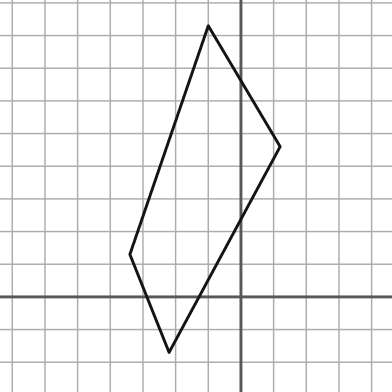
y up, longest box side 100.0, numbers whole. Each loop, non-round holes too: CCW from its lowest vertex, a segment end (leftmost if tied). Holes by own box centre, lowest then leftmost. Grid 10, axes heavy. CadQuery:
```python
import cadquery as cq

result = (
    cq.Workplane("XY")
    .moveTo(-22.0, -17.0)
    .lineTo(12.0, 46.0)
    .lineTo(-10.0, 83.0)
    .lineTo(-34.0, 13.0)
    .close()
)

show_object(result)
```